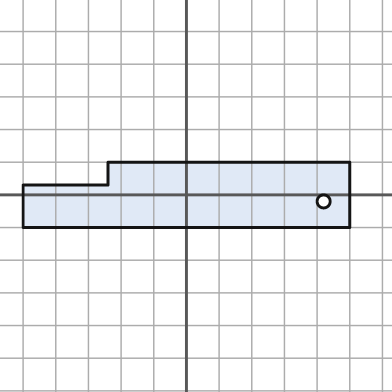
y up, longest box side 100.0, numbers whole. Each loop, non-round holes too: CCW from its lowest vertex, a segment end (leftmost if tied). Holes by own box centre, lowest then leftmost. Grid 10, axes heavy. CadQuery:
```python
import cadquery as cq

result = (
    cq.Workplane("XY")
    .moveTo(-50.0, -10.0)
    .lineTo(50.0, -10.0)
    .lineTo(50.0, 10.0)
    .lineTo(-24.0, 10.0)
    .lineTo(-24.0, 3.0)
    .lineTo(-50.0, 3.0)
    .close()
    .moveTo(42.0, -2.0)
    .circle(2.0)
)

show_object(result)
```